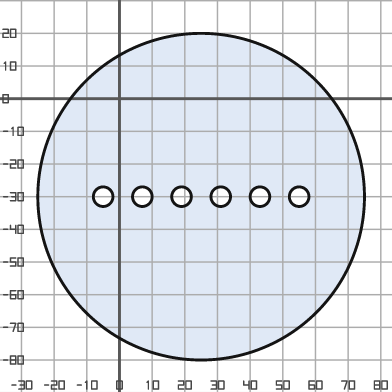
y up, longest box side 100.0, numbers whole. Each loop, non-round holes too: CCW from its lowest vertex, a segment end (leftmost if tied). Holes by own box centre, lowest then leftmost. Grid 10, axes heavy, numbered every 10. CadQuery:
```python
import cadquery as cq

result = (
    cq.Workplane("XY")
    .moveTo(25.0, -30.0)
    .circle(50.0)
    .moveTo(-5.0, -30.0)
    .circle(3.0)
    .moveTo(7.0, -30.0)
    .circle(3.0)
    .moveTo(19.0, -30.0)
    .circle(3.0)
    .moveTo(31.0, -30.0)
    .circle(3.0)
    .moveTo(43.0, -30.0)
    .circle(3.0)
    .moveTo(55.0, -30.0)
    .circle(3.0)
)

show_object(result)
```